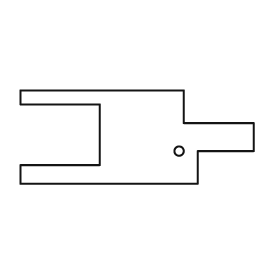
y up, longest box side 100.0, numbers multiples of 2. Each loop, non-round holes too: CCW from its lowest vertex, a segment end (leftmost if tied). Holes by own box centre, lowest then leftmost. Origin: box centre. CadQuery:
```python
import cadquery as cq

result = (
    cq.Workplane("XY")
    .moveTo(-50.0, -20.0)
    .lineTo(26.0, -20.0)
    .lineTo(26.0, -6.0)
    .lineTo(50.0, -6.0)
    .lineTo(50.0, 6.0)
    .lineTo(20.0, 6.0)
    .lineTo(20.0, 20.0)
    .lineTo(-50.0, 20.0)
    .lineTo(-50.0, 14.0)
    .lineTo(-16.0, 14.0)
    .lineTo(-16.0, -12.0)
    .lineTo(-50.0, -12.0)
    .close()
    .moveTo(18.0, -6.0)
    .circle(2.0)
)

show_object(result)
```